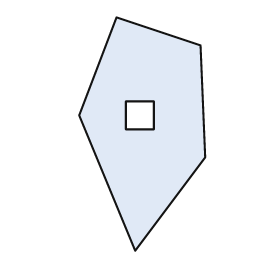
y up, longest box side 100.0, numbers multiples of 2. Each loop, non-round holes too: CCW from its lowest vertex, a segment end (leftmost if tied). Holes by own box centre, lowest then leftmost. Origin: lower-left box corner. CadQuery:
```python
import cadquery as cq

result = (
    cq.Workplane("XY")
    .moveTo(24.0, 0.0)
    .lineTo(54.0, 40.0)
    .lineTo(52.0, 88.0)
    .lineTo(16.0, 100.0)
    .lineTo(0.0, 58.0)
    .close()
    .moveTo(20.0, 52.0)
    .lineTo(32.0, 52.0)
    .lineTo(32.0, 64.0)
    .lineTo(20.0, 64.0)
    .close()
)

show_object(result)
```